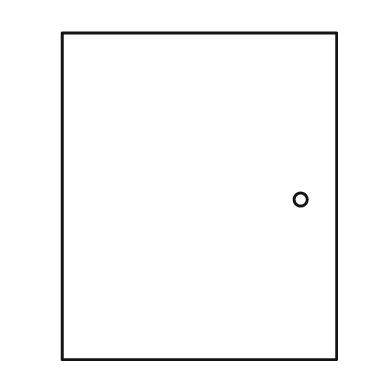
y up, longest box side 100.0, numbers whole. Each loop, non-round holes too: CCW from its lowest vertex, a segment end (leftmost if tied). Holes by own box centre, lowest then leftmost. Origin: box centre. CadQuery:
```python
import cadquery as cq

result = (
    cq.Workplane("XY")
    .moveTo(-42.0, -50.0)
    .lineTo(42.0, -50.0)
    .lineTo(42.0, 50.0)
    .lineTo(-42.0, 50.0)
    .close()
    .moveTo(31.0, -1.0)
    .circle(2.0)
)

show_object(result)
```